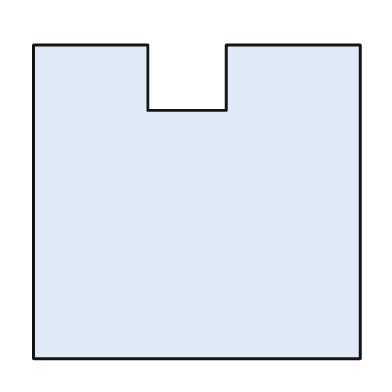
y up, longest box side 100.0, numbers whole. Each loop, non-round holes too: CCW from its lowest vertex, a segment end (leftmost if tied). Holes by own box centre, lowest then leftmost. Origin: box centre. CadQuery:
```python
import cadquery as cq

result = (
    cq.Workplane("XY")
    .moveTo(-50.0, -48.0)
    .lineTo(50.0, -48.0)
    .lineTo(50.0, 48.0)
    .lineTo(9.0, 48.0)
    .lineTo(9.0, 28.0)
    .lineTo(-15.0, 28.0)
    .lineTo(-15.0, 48.0)
    .lineTo(-50.0, 48.0)
    .close()
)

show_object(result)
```